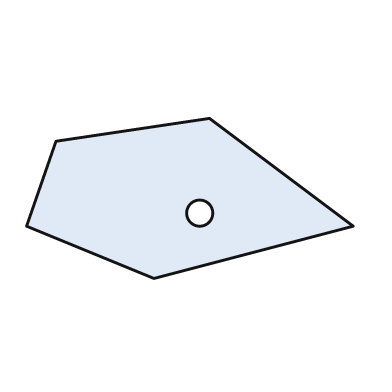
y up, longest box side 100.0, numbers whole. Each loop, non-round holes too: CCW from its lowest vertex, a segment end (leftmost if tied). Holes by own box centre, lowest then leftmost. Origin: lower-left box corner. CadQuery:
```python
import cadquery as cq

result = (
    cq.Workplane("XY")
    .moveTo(39.0, 0.0)
    .lineTo(100.0, 16.0)
    .lineTo(56.0, 49.0)
    .lineTo(9.0, 42.0)
    .lineTo(0.0, 16.0)
    .close()
    .moveTo(53.0, 20.0)
    .circle(4.0)
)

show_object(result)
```